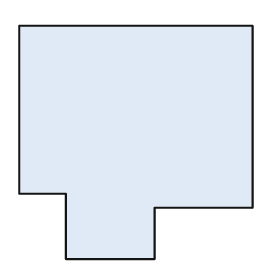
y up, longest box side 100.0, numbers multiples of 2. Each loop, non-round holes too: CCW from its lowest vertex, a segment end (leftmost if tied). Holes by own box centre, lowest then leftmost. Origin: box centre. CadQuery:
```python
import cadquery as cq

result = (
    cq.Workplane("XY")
    .moveTo(-30.0, -50.0)
    .lineTo(8.0, -50.0)
    .lineTo(8.0, -28.0)
    .lineTo(50.0, -28.0)
    .lineTo(50.0, 50.0)
    .lineTo(-50.0, 50.0)
    .lineTo(-50.0, -22.0)
    .lineTo(-30.0, -22.0)
    .close()
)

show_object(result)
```